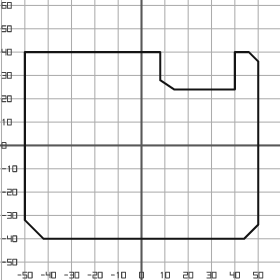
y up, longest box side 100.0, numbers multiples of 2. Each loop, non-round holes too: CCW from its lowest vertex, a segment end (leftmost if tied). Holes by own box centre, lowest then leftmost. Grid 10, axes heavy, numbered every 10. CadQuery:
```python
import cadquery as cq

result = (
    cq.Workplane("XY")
    .moveTo(-42.0, -40.0)
    .lineTo(44.0, -40.0)
    .lineTo(50.0, -34.0)
    .lineTo(50.0, 36.0)
    .lineTo(46.0, 40.0)
    .lineTo(40.0, 40.0)
    .lineTo(40.0, 24.0)
    .lineTo(14.0, 24.0)
    .lineTo(8.0, 28.0)
    .lineTo(8.0, 40.0)
    .lineTo(-50.0, 40.0)
    .lineTo(-50.0, -32.0)
    .close()
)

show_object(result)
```